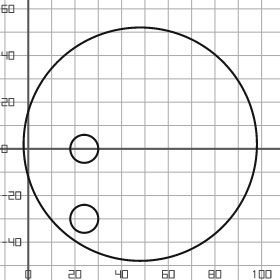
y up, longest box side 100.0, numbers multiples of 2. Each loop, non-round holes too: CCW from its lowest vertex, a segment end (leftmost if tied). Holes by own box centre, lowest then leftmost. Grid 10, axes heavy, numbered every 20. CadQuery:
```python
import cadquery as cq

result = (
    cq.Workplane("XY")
    .moveTo(48.0, 2.0)
    .circle(50.0)
    .moveTo(24.0, -30.0)
    .circle(6.0)
    .moveTo(24.0, 0.0)
    .circle(6.0)
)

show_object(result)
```